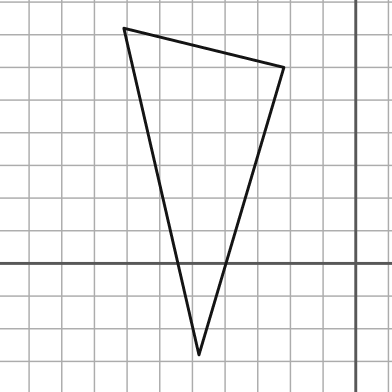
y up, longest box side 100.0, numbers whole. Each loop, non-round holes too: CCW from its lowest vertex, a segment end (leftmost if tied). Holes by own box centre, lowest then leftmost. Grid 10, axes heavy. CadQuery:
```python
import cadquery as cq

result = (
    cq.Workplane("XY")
    .moveTo(-48.0, -28.0)
    .lineTo(-22.0, 60.0)
    .lineTo(-71.0, 72.0)
    .close()
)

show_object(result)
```